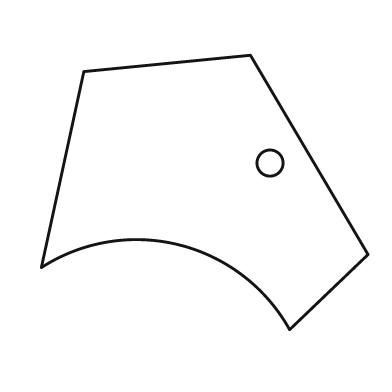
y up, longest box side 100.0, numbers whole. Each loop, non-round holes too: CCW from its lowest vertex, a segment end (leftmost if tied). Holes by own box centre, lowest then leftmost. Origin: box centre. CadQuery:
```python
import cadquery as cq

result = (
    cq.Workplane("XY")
    .moveTo(26.0, -42.0)
    .lineTo(50.0, -19.0)
    .lineTo(14.0, 42.0)
    .lineTo(-37.0, 37.0)
    .lineTo(-50.0, -23.0)
    .threePointArc((-8.0, -16.0), (26.0, -42.0))
    .close()
    .moveTo(20.0, 9.0)
    .circle(4.0)
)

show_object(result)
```